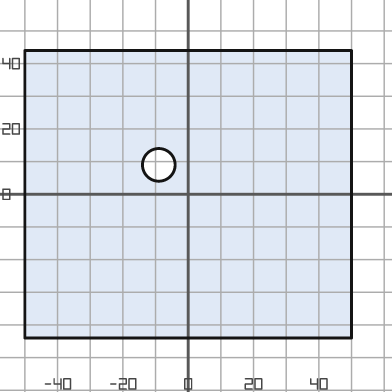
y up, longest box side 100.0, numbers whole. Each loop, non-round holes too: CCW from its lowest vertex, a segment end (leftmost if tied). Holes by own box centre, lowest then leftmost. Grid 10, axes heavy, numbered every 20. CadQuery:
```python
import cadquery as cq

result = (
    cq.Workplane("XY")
    .moveTo(-50.0, -44.0)
    .lineTo(50.0, -44.0)
    .lineTo(50.0, 44.0)
    .lineTo(-50.0, 44.0)
    .close()
    .moveTo(-9.0, 9.0)
    .circle(5.0)
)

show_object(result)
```